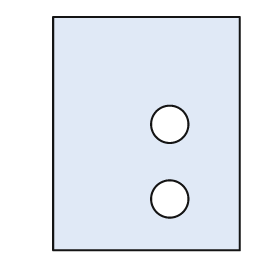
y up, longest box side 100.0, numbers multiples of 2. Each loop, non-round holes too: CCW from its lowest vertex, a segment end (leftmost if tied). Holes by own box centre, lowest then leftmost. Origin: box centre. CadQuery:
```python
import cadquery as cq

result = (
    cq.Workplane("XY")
    .moveTo(-40.0, -50.0)
    .lineTo(40.0, -50.0)
    .lineTo(40.0, 50.0)
    .lineTo(-40.0, 50.0)
    .close()
    .moveTo(10.0, -28.0)
    .circle(8.0)
    .moveTo(10.0, 4.0)
    .circle(8.0)
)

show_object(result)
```